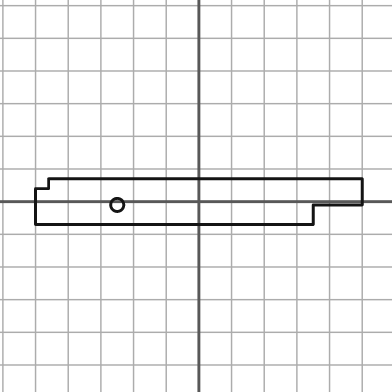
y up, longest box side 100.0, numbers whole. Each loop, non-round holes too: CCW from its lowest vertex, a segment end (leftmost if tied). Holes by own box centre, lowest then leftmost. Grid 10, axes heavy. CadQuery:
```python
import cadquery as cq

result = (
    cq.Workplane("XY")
    .moveTo(-50.0, -7.0)
    .lineTo(35.0, -7.0)
    .lineTo(35.0, -1.0)
    .lineTo(50.0, -1.0)
    .lineTo(50.0, 7.0)
    .lineTo(-46.0, 7.0)
    .lineTo(-46.0, 4.0)
    .lineTo(-50.0, 4.0)
    .close()
    .moveTo(-25.0, -1.0)
    .circle(2.0)
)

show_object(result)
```